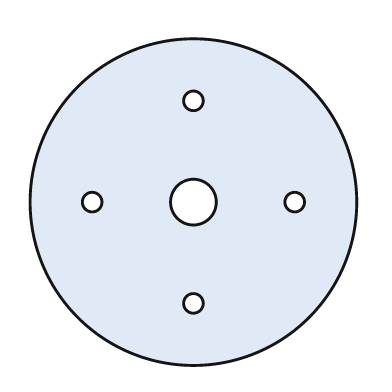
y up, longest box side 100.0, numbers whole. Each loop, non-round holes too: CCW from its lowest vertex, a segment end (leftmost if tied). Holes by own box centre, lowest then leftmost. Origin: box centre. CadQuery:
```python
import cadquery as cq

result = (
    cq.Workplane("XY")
    .moveTo(0.0, 0.0)
    .circle(50.0)
    .moveTo(0.0, -31.0)
    .circle(3.0)
    .moveTo(-31.0, 0.0)
    .circle(3.0)
    .moveTo(0.0, 0.0)
    .circle(7.0)
    .moveTo(31.0, 0.0)
    .circle(3.0)
    .moveTo(0.0, 31.0)
    .circle(3.0)
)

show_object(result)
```